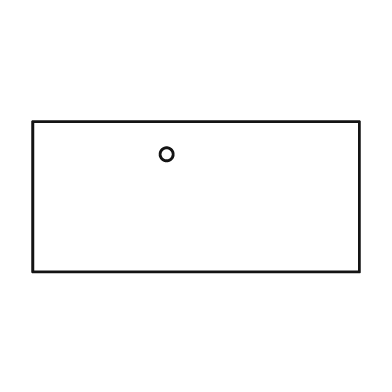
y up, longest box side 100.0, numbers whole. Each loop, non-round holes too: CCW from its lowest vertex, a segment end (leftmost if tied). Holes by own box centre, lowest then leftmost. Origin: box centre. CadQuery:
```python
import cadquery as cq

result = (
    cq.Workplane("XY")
    .moveTo(-50.0, -23.0)
    .lineTo(50.0, -23.0)
    .lineTo(50.0, 23.0)
    .lineTo(-50.0, 23.0)
    .close()
    .moveTo(-9.0, 13.0)
    .circle(2.0)
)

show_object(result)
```